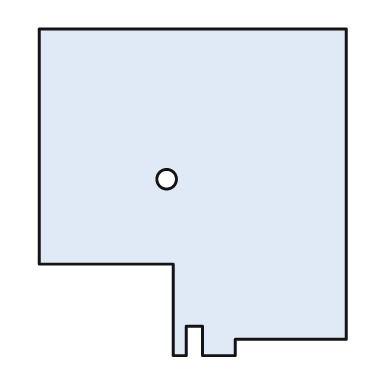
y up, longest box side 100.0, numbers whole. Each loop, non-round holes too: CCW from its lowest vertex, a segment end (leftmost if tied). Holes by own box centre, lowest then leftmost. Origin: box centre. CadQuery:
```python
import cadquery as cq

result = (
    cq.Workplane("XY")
    .moveTo(-6.0, -50.0)
    .lineTo(-2.0, -50.0)
    .lineTo(-2.0, -41.0)
    .lineTo(3.0, -41.0)
    .lineTo(3.0, -50.0)
    .lineTo(13.0, -50.0)
    .lineTo(13.0, -45.0)
    .lineTo(47.0, -45.0)
    .lineTo(47.0, 50.0)
    .lineTo(-47.0, 50.0)
    .lineTo(-47.0, -22.0)
    .lineTo(-6.0, -22.0)
    .close()
    .moveTo(-8.0, 4.0)
    .circle(3.0)
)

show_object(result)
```